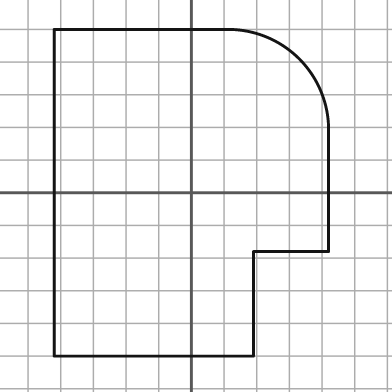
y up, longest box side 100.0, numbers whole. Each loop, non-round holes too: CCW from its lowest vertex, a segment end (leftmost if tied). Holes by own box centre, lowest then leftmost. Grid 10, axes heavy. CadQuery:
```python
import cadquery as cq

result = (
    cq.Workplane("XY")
    .moveTo(-42.0, -50.0)
    .lineTo(19.0, -50.0)
    .lineTo(19.0, -18.0)
    .lineTo(42.0, -18.0)
    .lineTo(42.0, 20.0)
    .threePointArc((33.0, 41.0), (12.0, 50.0))
    .lineTo(-42.0, 50.0)
    .close()
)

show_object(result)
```